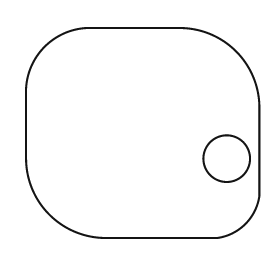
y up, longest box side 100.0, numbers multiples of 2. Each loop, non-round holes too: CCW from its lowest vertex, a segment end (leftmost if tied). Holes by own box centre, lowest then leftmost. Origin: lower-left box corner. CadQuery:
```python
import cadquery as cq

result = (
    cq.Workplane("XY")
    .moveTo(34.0, 0.0)
    .lineTo(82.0, 0.0)
    .threePointArc((94.0, 6.0), (100.0, 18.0))
    .lineTo(100.0, 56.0)
    .threePointArc((90.0, 80.0), (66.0, 90.0))
    .lineTo(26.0, 90.0)
    .threePointArc((8.0, 82.0), (0.0, 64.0))
    .lineTo(0.0, 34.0)
    .threePointArc((10.0, 10.0), (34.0, 0.0))
    .close()
    .moveTo(86.0, 34.0)
    .circle(10.0)
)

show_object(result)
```